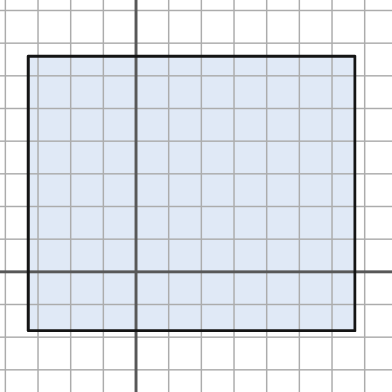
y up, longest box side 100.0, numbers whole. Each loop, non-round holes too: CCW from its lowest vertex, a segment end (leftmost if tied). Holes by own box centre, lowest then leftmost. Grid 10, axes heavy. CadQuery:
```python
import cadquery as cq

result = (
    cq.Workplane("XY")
    .moveTo(-33.0, -18.0)
    .lineTo(67.0, -18.0)
    .lineTo(67.0, 66.0)
    .lineTo(-33.0, 66.0)
    .close()
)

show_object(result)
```